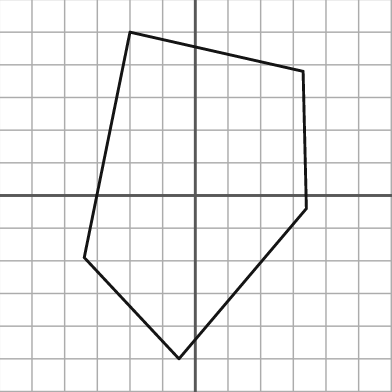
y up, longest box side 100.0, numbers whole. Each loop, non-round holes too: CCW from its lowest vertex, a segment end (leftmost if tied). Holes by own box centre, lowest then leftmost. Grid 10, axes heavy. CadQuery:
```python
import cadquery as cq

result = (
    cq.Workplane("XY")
    .moveTo(-5.0, -50.0)
    .lineTo(34.0, -4.0)
    .lineTo(33.0, 38.0)
    .lineTo(-20.0, 50.0)
    .lineTo(-34.0, -19.0)
    .close()
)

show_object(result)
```